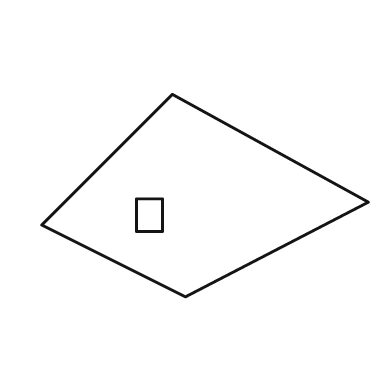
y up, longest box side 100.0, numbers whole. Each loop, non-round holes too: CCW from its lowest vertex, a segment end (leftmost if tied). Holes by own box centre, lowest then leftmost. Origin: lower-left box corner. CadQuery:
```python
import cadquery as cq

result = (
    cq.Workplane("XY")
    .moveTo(44.0, 0.0)
    .lineTo(100.0, 29.0)
    .lineTo(40.0, 62.0)
    .lineTo(0.0, 22.0)
    .close()
    .moveTo(29.0, 20.0)
    .lineTo(37.0, 20.0)
    .lineTo(37.0, 30.0)
    .lineTo(29.0, 30.0)
    .close()
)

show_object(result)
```